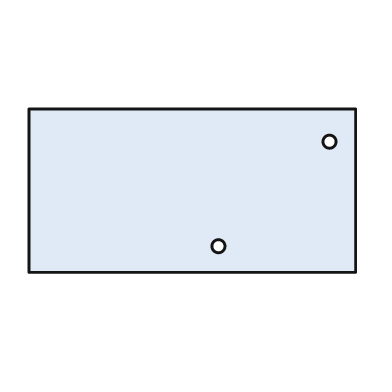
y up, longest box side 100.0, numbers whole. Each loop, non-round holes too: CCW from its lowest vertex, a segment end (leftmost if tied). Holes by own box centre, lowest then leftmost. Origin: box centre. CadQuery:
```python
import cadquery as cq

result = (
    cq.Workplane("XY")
    .moveTo(-50.0, -25.0)
    .lineTo(50.0, -25.0)
    .lineTo(50.0, 25.0)
    .lineTo(-50.0, 25.0)
    .close()
    .moveTo(8.0, -17.0)
    .circle(2.0)
    .moveTo(42.0, 15.0)
    .circle(2.0)
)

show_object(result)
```